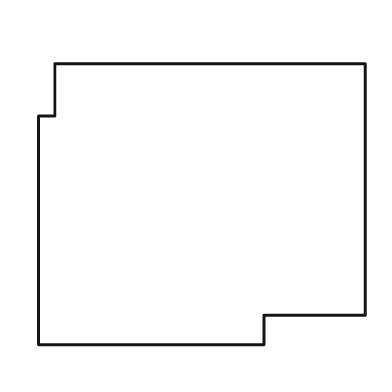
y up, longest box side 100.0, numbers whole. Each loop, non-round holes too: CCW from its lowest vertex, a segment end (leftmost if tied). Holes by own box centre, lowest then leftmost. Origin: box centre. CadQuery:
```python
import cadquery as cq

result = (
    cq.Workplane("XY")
    .moveTo(-50.0, -43.0)
    .lineTo(19.0, -43.0)
    .lineTo(19.0, -34.0)
    .lineTo(50.0, -34.0)
    .lineTo(50.0, 43.0)
    .lineTo(-45.0, 43.0)
    .lineTo(-45.0, 27.0)
    .lineTo(-50.0, 27.0)
    .close()
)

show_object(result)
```